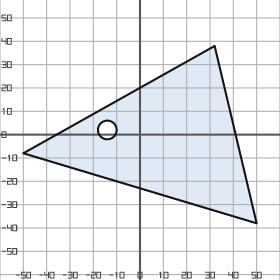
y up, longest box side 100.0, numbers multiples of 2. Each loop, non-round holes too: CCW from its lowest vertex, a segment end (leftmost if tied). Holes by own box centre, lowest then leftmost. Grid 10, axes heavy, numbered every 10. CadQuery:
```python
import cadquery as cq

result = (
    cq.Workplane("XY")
    .moveTo(50.0, -38.0)
    .lineTo(32.0, 38.0)
    .lineTo(-50.0, -8.0)
    .close()
    .moveTo(-14.0, 2.0)
    .circle(4.0)
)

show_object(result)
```